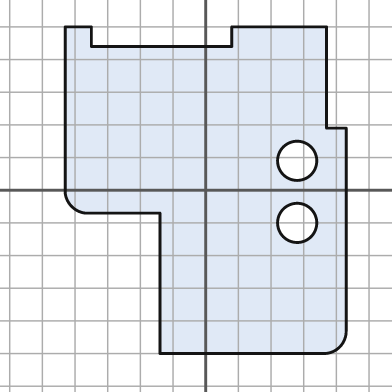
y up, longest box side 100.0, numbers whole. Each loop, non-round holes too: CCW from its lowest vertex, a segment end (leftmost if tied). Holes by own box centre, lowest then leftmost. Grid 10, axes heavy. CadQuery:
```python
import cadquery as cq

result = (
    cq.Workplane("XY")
    .moveTo(-14.0, -50.0)
    .lineTo(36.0, -50.0)
    .threePointArc((41.0, -48.0), (43.0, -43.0))
    .lineTo(43.0, 19.0)
    .lineTo(37.0, 19.0)
    .lineTo(37.0, 50.0)
    .lineTo(8.0, 50.0)
    .lineTo(8.0, 44.0)
    .lineTo(-35.0, 44.0)
    .lineTo(-35.0, 50.0)
    .lineTo(-43.0, 50.0)
    .lineTo(-43.0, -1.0)
    .threePointArc((-41.0, -5.0), (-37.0, -7.0))
    .lineTo(-14.0, -7.0)
    .close()
    .moveTo(28.0, -10.0)
    .circle(6.0)
    .moveTo(28.0, 9.0)
    .circle(6.0)
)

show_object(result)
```